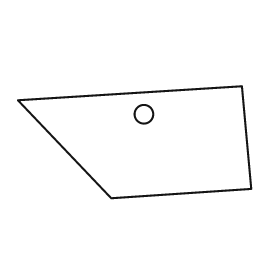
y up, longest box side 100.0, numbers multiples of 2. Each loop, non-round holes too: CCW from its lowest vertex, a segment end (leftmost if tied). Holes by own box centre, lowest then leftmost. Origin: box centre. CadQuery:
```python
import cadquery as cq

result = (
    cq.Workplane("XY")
    .moveTo(-10.0, -24.0)
    .lineTo(50.0, -20.0)
    .lineTo(46.0, 24.0)
    .lineTo(-50.0, 18.0)
    .close()
    .moveTo(4.0, 12.0)
    .circle(4.0)
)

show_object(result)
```